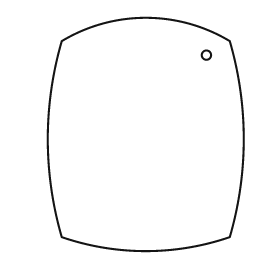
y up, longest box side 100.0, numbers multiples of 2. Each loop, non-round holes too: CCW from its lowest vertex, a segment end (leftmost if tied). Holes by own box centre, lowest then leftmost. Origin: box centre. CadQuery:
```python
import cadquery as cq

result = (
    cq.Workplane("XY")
    .moveTo(-36.0, -44.0)
    .threePointArc((0.0, -50.0), (36.0, -44.0))
    .threePointArc((42.0, -2.0), (36.0, 40.0))
    .threePointArc((0.0, 50.0), (-36.0, 40.0))
    .threePointArc((-42.0, -2.0), (-36.0, -44.0))
    .close()
    .moveTo(26.0, 34.0)
    .circle(2.0)
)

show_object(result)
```